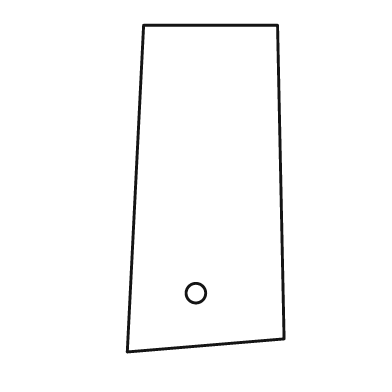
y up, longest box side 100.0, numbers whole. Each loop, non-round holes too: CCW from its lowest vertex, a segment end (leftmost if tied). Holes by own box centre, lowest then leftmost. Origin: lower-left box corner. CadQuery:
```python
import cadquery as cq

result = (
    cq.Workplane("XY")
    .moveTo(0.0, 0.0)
    .lineTo(48.0, 4.0)
    .lineTo(46.0, 100.0)
    .lineTo(5.0, 100.0)
    .close()
    .moveTo(21.0, 18.0)
    .circle(3.0)
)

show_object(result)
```